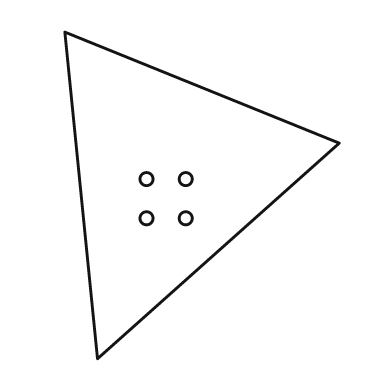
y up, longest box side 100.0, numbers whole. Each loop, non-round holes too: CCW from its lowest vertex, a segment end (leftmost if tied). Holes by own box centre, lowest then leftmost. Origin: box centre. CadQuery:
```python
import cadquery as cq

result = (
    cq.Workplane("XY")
    .moveTo(-32.0, -50.0)
    .lineTo(42.0, 16.0)
    .lineTo(-42.0, 50.0)
    .close()
    .moveTo(-17.0, -7.0)
    .circle(2.0)
    .moveTo(-5.0, -7.0)
    .circle(2.0)
    .moveTo(-17.0, 5.0)
    .circle(2.0)
    .moveTo(-5.0, 5.0)
    .circle(2.0)
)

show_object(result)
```